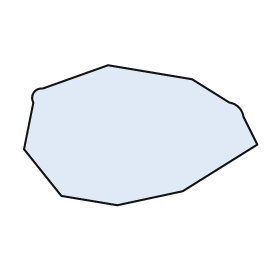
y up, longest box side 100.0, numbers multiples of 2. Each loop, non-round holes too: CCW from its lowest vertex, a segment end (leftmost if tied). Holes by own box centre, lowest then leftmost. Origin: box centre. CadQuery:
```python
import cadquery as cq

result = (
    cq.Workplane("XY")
    .moveTo(-10.0, -30.0)
    .lineTo(18.0, -24.0)
    .lineTo(50.0, -4.0)
    .lineTo(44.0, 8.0)
    .threePointArc((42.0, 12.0), (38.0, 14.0))
    .lineTo(22.0, 24.0)
    .lineTo(-14.0, 30.0)
    .lineTo(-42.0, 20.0)
    .threePointArc((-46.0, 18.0), (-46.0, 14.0))
    .lineTo(-50.0, -6.0)
    .lineTo(-34.0, -26.0)
    .close()
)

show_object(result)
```